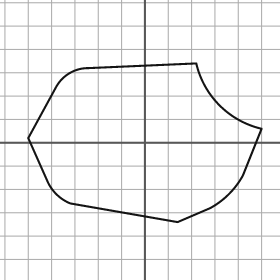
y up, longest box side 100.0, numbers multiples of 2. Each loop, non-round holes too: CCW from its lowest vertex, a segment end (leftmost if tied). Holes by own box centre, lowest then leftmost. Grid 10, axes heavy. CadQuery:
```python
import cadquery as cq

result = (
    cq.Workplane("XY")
    .moveTo(14.0, -34.0)
    .lineTo(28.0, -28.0)
    .threePointArc((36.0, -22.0), (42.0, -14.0))
    .lineTo(50.0, 6.0)
    .threePointArc((32.0, 16.0), (22.0, 34.0))
    .lineTo(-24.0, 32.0)
    .threePointArc((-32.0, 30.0), (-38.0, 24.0))
    .lineTo(-50.0, 2.0)
    .lineTo(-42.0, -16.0)
    .threePointArc((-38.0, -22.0), (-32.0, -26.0))
    .close()
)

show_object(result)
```